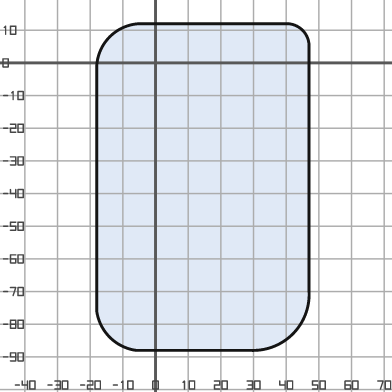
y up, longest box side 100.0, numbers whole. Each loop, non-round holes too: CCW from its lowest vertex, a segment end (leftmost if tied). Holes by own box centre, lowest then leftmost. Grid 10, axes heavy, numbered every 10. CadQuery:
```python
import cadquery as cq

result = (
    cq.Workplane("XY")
    .moveTo(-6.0, -88.0)
    .lineTo(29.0, -88.0)
    .threePointArc((42.0, -83.0), (47.0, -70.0))
    .lineTo(47.0, 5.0)
    .threePointArc((45.0, 10.0), (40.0, 12.0))
    .lineTo(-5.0, 12.0)
    .threePointArc((-14.0, 8.0), (-18.0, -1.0))
    .lineTo(-18.0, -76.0)
    .threePointArc((-14.0, -84.0), (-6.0, -88.0))
    .close()
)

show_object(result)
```